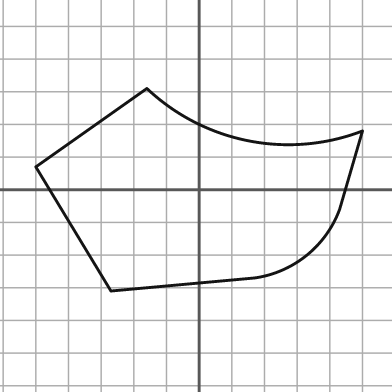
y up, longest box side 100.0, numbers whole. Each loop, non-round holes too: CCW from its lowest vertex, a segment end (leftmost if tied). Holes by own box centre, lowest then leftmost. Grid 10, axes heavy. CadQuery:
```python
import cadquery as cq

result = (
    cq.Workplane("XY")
    .moveTo(-27.0, -31.0)
    .lineTo(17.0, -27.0)
    .threePointArc((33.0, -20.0), (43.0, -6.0))
    .lineTo(50.0, 18.0)
    .threePointArc((15.0, 15.0), (-16.0, 31.0))
    .lineTo(-50.0, 7.0)
    .close()
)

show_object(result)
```